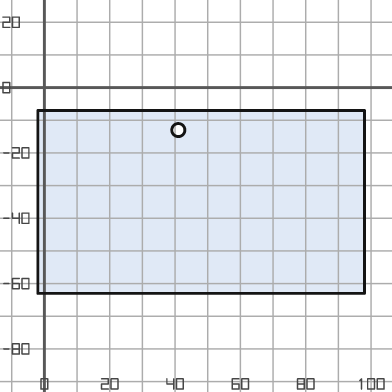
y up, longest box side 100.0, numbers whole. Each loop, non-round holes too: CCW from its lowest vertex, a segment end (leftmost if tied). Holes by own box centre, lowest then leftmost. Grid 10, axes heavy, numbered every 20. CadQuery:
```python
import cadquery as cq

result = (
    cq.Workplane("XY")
    .moveTo(-2.0, -63.0)
    .lineTo(98.0, -63.0)
    .lineTo(98.0, -7.0)
    .lineTo(-2.0, -7.0)
    .close()
    .moveTo(41.0, -13.0)
    .circle(2.0)
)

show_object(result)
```